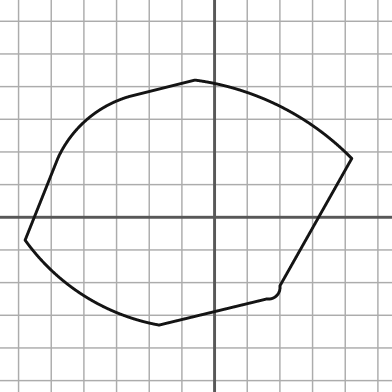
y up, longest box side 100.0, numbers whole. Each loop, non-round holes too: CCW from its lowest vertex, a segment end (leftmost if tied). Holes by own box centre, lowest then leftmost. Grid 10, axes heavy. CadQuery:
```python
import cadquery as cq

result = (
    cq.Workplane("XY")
    .moveTo(-17.0, -33.0)
    .lineTo(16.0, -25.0)
    .threePointArc((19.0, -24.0), (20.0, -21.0))
    .lineTo(42.0, 18.0)
    .threePointArc((20.0, 34.0), (-6.0, 42.0))
    .lineTo(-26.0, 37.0)
    .threePointArc((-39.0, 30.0), (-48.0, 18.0))
    .lineTo(-58.0, -7.0)
    .threePointArc((-40.0, -24.0), (-17.0, -33.0))
    .close()
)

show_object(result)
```